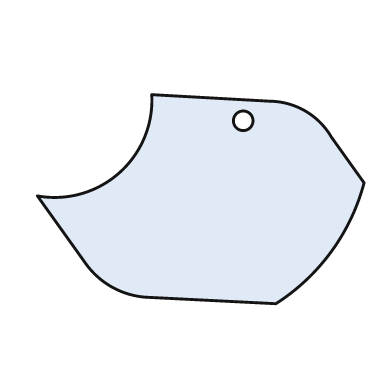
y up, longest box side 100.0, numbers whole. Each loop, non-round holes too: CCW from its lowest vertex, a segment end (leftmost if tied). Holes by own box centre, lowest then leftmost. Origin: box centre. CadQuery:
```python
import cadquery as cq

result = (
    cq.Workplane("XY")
    .moveTo(23.0, -32.0)
    .threePointArc((40.0, -16.0), (50.0, 5.0))
    .lineTo(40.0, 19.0)
    .threePointArc((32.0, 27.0), (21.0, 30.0))
    .lineTo(-15.0, 32.0)
    .threePointArc((-25.0, 8.0), (-50.0, 1.0))
    .lineTo(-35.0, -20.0)
    .threePointArc((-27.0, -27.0), (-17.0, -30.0))
    .close()
    .moveTo(13.0, 24.0)
    .circle(3.0)
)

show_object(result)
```